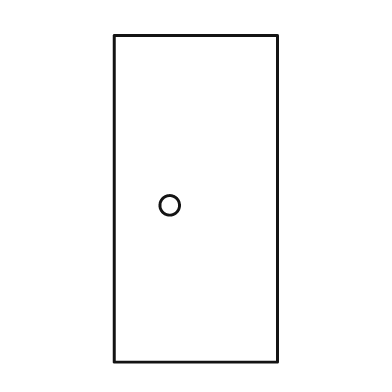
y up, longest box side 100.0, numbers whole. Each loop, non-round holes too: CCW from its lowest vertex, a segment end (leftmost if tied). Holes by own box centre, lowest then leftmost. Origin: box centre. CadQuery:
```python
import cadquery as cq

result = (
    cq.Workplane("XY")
    .moveTo(-25.0, -50.0)
    .lineTo(25.0, -50.0)
    .lineTo(25.0, 50.0)
    .lineTo(-25.0, 50.0)
    .close()
    .moveTo(-8.0, -2.0)
    .circle(3.0)
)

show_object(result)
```